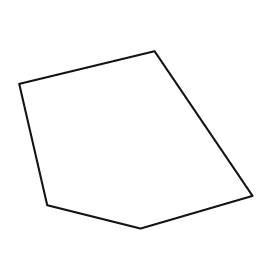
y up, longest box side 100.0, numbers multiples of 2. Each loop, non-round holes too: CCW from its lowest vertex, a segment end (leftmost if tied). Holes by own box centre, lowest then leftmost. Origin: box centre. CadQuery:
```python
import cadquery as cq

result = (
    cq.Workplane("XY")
    .moveTo(2.0, -38.0)
    .lineTo(50.0, -24.0)
    .lineTo(8.0, 38.0)
    .lineTo(-50.0, 24.0)
    .lineTo(-38.0, -28.0)
    .close()
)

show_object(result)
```